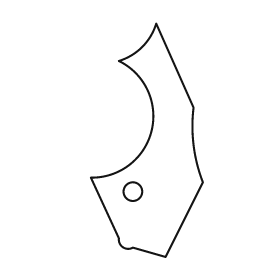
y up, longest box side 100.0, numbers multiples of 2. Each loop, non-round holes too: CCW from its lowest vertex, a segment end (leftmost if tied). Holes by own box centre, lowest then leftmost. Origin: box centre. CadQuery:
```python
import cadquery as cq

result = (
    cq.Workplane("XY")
    .moveTo(8.0, -50.0)
    .lineTo(24.0, -18.0)
    .threePointArc((20.0, -2.0), (20.0, 14.0))
    .lineTo(4.0, 50.0)
    .threePointArc((-2.0, 40.0), (-12.0, 34.0))
    .threePointArc((2.0, 4.0), (-24.0, -16.0))
    .lineTo(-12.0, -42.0)
    .threePointArc((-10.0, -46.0), (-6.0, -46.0))
    .close()
    .moveTo(-6.0, -22.0)
    .circle(4.0)
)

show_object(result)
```